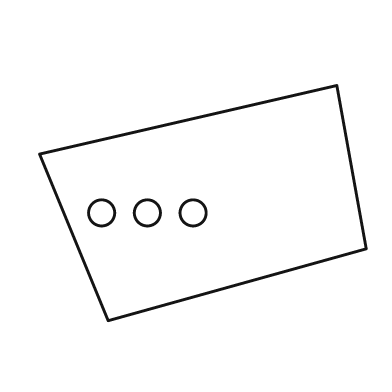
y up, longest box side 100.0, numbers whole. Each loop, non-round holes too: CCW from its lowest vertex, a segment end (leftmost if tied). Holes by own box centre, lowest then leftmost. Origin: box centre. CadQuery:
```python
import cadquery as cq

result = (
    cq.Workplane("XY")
    .moveTo(-29.0, -36.0)
    .lineTo(50.0, -14.0)
    .lineTo(41.0, 36.0)
    .lineTo(-50.0, 15.0)
    .close()
    .moveTo(-31.0, -3.0)
    .circle(4.0)
    .moveTo(-17.0, -3.0)
    .circle(4.0)
    .moveTo(-3.0, -3.0)
    .circle(4.0)
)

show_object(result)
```